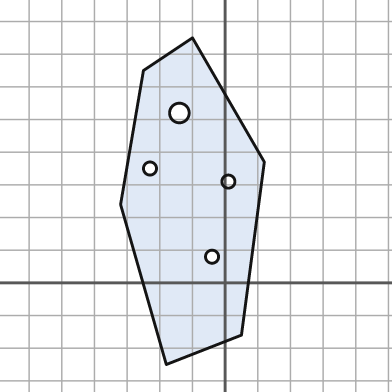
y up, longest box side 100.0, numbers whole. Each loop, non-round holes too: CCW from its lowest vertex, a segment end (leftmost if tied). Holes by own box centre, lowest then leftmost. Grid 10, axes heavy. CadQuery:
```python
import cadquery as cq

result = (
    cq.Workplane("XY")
    .moveTo(-18.0, -25.0)
    .lineTo(5.0, -16.0)
    .lineTo(12.0, 37.0)
    .lineTo(-10.0, 75.0)
    .lineTo(-25.0, 65.0)
    .lineTo(-32.0, 24.0)
    .close()
    .moveTo(-4.0, 8.0)
    .circle(2.0)
    .moveTo(1.0, 31.0)
    .circle(2.0)
    .moveTo(-23.0, 35.0)
    .circle(2.0)
    .moveTo(-14.0, 52.0)
    .circle(3.0)
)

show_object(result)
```